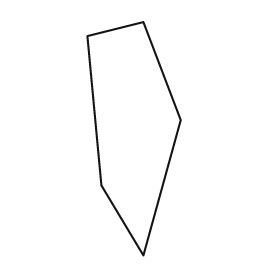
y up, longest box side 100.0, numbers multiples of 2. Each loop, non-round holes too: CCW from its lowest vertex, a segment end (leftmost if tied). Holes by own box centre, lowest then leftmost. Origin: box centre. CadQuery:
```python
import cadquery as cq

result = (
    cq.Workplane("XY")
    .moveTo(4.0, -50.0)
    .lineTo(20.0, 8.0)
    .lineTo(4.0, 50.0)
    .lineTo(-20.0, 44.0)
    .lineTo(-14.0, -20.0)
    .close()
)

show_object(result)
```